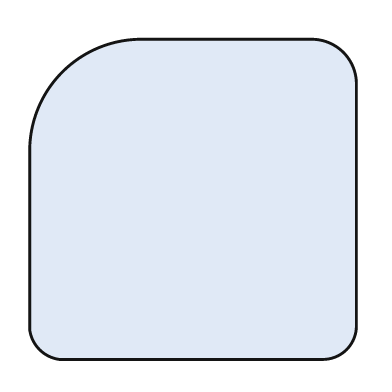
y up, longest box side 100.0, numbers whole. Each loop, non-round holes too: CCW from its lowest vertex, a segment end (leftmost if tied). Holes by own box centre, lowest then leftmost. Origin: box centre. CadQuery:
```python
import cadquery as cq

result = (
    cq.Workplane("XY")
    .moveTo(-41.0, -49.0)
    .lineTo(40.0, -49.0)
    .threePointArc((47.0, -46.0), (50.0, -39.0))
    .lineTo(50.0, 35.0)
    .threePointArc((46.0, 45.0), (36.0, 49.0))
    .lineTo(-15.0, 49.0)
    .threePointArc((-40.0, 39.0), (-50.0, 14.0))
    .lineTo(-50.0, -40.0)
    .threePointArc((-47.0, -46.0), (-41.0, -49.0))
    .close()
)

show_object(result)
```